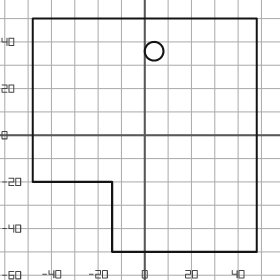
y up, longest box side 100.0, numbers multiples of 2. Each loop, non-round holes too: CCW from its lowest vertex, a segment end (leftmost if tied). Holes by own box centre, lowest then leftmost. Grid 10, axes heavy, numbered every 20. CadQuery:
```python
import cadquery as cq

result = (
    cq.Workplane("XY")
    .moveTo(-14.0, -50.0)
    .lineTo(48.0, -50.0)
    .lineTo(48.0, 50.0)
    .lineTo(-48.0, 50.0)
    .lineTo(-48.0, -20.0)
    .lineTo(-14.0, -20.0)
    .close()
    .moveTo(4.0, 36.0)
    .circle(4.0)
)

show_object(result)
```